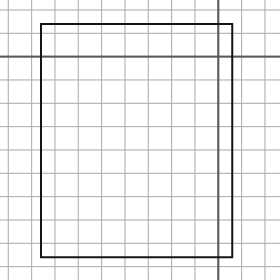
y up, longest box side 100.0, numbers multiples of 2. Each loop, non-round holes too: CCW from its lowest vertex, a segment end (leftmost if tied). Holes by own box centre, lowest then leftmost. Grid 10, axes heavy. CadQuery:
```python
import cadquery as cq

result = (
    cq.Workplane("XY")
    .moveTo(-76.0, -86.0)
    .lineTo(6.0, -86.0)
    .lineTo(6.0, 14.0)
    .lineTo(-76.0, 14.0)
    .close()
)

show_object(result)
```